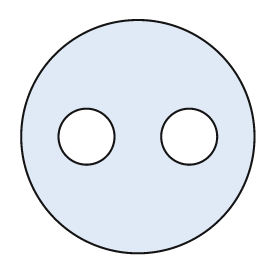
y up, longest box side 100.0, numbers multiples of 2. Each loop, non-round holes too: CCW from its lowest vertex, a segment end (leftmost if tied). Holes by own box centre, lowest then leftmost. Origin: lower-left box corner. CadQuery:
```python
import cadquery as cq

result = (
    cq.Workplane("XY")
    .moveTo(50.0, 50.0)
    .circle(50.0)
    .moveTo(28.0, 50.0)
    .circle(12.0)
    .moveTo(72.0, 50.0)
    .circle(12.0)
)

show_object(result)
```